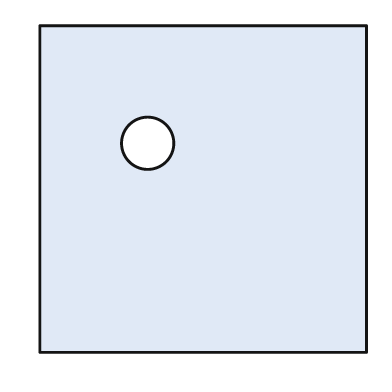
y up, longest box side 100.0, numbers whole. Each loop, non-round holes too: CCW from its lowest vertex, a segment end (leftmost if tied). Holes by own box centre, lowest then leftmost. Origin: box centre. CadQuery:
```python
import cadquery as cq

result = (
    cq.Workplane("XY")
    .moveTo(-50.0, -50.0)
    .lineTo(50.0, -50.0)
    .lineTo(50.0, 50.0)
    .lineTo(-50.0, 50.0)
    .close()
    .moveTo(-17.0, 14.0)
    .circle(8.0)
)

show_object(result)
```